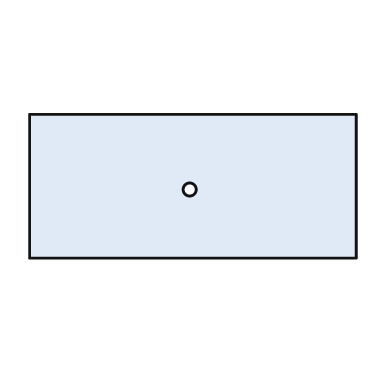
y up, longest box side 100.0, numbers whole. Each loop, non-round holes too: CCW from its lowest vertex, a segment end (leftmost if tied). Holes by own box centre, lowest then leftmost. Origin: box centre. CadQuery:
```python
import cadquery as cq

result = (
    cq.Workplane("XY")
    .moveTo(-50.0, -22.0)
    .lineTo(50.0, -22.0)
    .lineTo(50.0, 22.0)
    .lineTo(-50.0, 22.0)
    .close()
    .moveTo(-1.0, -1.0)
    .circle(2.0)
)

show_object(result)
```